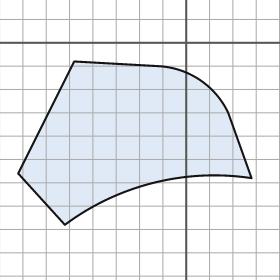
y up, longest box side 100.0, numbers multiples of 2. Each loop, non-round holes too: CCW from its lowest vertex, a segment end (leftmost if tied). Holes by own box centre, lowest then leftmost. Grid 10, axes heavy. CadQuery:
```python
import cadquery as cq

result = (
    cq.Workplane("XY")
    .moveTo(-52.0, -78.0)
    .threePointArc((-14.0, -60.0), (28.0, -58.0))
    .lineTo(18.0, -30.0)
    .threePointArc((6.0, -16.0), (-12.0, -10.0))
    .lineTo(-48.0, -8.0)
    .lineTo(-72.0, -56.0)
    .close()
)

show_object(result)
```